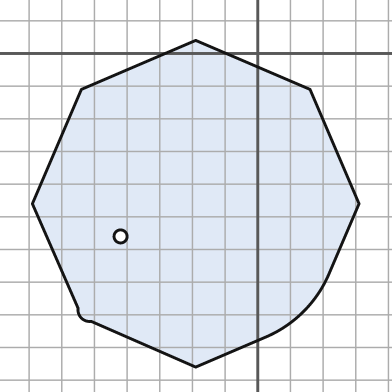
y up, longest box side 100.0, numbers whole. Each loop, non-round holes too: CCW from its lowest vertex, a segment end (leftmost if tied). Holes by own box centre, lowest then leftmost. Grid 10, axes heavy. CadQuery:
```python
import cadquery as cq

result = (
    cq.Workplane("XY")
    .moveTo(-19.0, -96.0)
    .lineTo(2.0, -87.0)
    .threePointArc((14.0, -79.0), (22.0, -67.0))
    .lineTo(31.0, -46.0)
    .lineTo(16.0, -11.0)
    .lineTo(-19.0, 4.0)
    .lineTo(-54.0, -11.0)
    .lineTo(-69.0, -46.0)
    .lineTo(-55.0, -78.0)
    .threePointArc((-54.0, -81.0), (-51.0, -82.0))
    .close()
    .moveTo(-42.0, -56.0)
    .circle(2.0)
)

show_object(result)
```